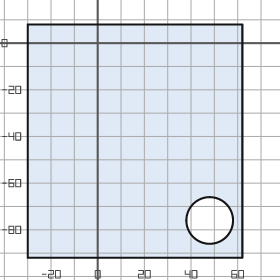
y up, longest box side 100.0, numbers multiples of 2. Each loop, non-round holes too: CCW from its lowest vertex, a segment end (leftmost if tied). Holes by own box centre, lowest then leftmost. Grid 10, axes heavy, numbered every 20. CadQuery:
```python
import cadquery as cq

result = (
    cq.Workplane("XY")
    .moveTo(-30.0, -92.0)
    .lineTo(62.0, -92.0)
    .lineTo(62.0, 8.0)
    .lineTo(-30.0, 8.0)
    .close()
    .moveTo(48.0, -76.0)
    .circle(10.0)
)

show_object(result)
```